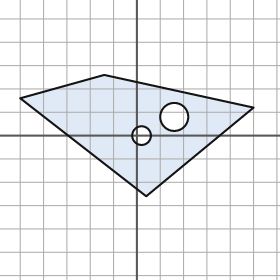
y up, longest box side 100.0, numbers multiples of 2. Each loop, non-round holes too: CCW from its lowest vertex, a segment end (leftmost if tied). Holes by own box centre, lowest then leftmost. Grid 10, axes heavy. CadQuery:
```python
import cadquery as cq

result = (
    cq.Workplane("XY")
    .moveTo(4.0, -26.0)
    .lineTo(50.0, 12.0)
    .lineTo(-14.0, 26.0)
    .lineTo(-50.0, 16.0)
    .close()
    .moveTo(2.0, 0.0)
    .circle(4.0)
    .moveTo(16.0, 8.0)
    .circle(6.0)
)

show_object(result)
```